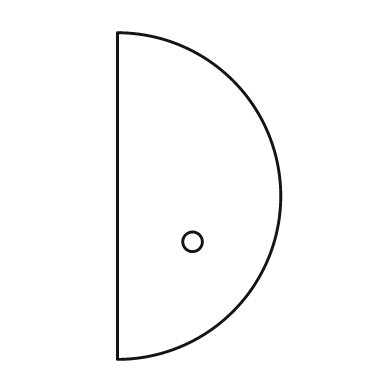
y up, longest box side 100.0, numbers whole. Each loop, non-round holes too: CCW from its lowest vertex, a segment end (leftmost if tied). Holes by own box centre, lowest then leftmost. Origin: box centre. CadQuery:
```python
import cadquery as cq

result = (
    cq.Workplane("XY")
    .moveTo(-25.0, -50.0)
    .threePointArc((25.0, 0.0), (-25.0, 50.0))
    .close()
    .moveTo(-2.0, -14.0)
    .circle(3.0)
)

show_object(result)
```